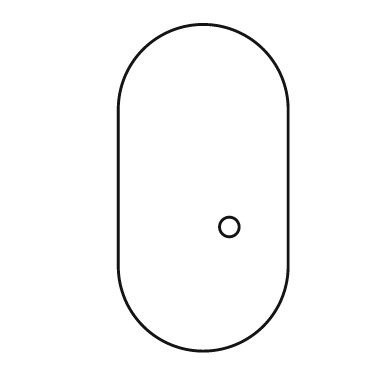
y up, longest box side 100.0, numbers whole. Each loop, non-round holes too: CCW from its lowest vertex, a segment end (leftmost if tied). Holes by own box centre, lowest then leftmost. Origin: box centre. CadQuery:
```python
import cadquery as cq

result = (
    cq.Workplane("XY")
    .moveTo(-26.0, -24.0)
    .threePointArc((0.0, -50.0), (26.0, -24.0))
    .lineTo(26.0, 24.0)
    .threePointArc((0.0, 50.0), (-26.0, 24.0))
    .close()
    .moveTo(8.0, -12.0)
    .circle(3.0)
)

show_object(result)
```